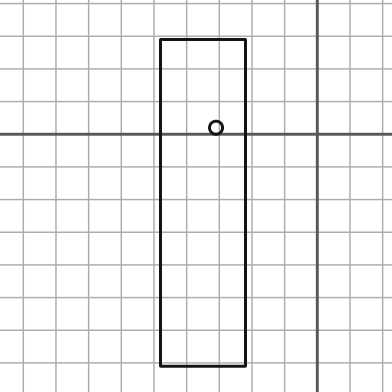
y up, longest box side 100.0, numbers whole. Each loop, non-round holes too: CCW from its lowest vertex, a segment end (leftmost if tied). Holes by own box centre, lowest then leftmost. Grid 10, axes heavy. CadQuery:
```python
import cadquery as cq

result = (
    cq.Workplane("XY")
    .moveTo(-48.0, -71.0)
    .lineTo(-22.0, -71.0)
    .lineTo(-22.0, 29.0)
    .lineTo(-48.0, 29.0)
    .close()
    .moveTo(-31.0, 2.0)
    .circle(2.0)
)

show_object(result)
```